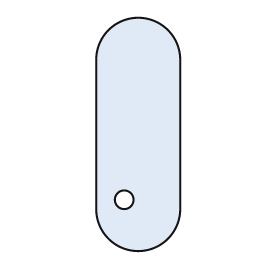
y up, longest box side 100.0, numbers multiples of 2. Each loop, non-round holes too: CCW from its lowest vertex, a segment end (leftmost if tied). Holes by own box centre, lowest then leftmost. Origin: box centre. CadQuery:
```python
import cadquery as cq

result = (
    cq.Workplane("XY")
    .moveTo(-18.0, -32.0)
    .threePointArc((0.0, -50.0), (18.0, -32.0))
    .lineTo(18.0, 32.0)
    .threePointArc((0.0, 50.0), (-18.0, 32.0))
    .close()
    .moveTo(-6.0, -28.0)
    .circle(4.0)
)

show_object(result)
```